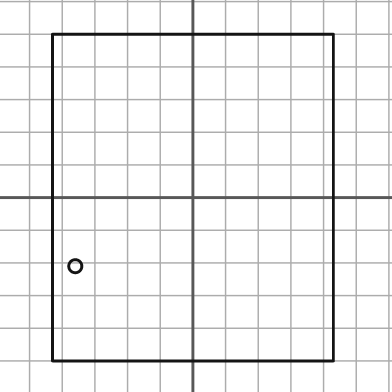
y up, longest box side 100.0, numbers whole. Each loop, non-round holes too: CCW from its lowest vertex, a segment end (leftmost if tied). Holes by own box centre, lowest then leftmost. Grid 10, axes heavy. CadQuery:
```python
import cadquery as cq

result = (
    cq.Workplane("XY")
    .moveTo(-43.0, -50.0)
    .lineTo(43.0, -50.0)
    .lineTo(43.0, 50.0)
    .lineTo(-43.0, 50.0)
    .close()
    .moveTo(-36.0, -21.0)
    .circle(2.0)
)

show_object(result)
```